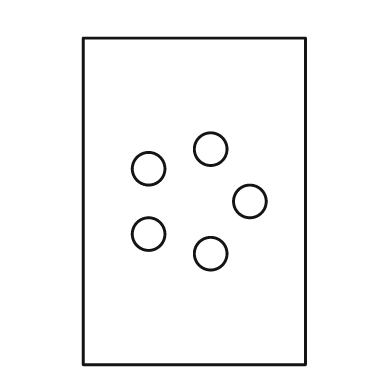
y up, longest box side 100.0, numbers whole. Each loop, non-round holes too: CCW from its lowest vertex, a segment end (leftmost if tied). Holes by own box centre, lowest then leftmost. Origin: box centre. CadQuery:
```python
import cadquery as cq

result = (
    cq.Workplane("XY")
    .moveTo(-34.0, -50.0)
    .lineTo(34.0, -50.0)
    .lineTo(34.0, 50.0)
    .lineTo(-34.0, 50.0)
    .close()
    .moveTo(5.0, -16.0)
    .circle(5.0)
    .moveTo(-14.0, -10.0)
    .circle(5.0)
    .moveTo(17.0, 0.0)
    .circle(5.0)
    .moveTo(-14.0, 10.0)
    .circle(5.0)
    .moveTo(5.0, 16.0)
    .circle(5.0)
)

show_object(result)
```